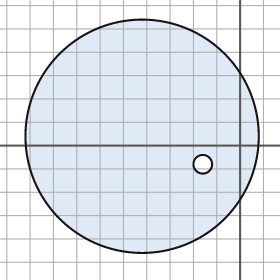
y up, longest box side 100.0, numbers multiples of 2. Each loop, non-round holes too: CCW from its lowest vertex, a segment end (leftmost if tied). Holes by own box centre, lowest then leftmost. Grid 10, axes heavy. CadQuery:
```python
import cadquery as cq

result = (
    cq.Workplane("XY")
    .moveTo(-42.0, 4.0)
    .circle(50.0)
    .moveTo(-16.0, -8.0)
    .circle(4.0)
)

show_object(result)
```